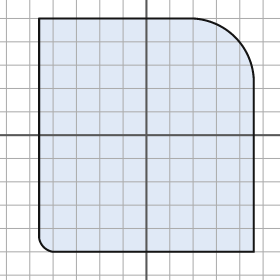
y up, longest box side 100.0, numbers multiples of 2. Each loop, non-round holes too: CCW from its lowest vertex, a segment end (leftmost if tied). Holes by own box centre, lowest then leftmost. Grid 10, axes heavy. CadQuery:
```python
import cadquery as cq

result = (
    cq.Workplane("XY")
    .moveTo(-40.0, -50.0)
    .lineTo(46.0, -50.0)
    .lineTo(46.0, 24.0)
    .threePointArc((38.0, 42.0), (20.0, 50.0))
    .lineTo(-46.0, 50.0)
    .lineTo(-46.0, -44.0)
    .threePointArc((-44.0, -48.0), (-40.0, -50.0))
    .close()
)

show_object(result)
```